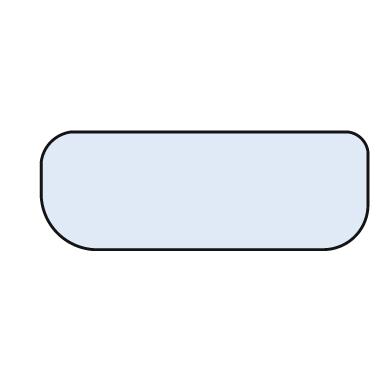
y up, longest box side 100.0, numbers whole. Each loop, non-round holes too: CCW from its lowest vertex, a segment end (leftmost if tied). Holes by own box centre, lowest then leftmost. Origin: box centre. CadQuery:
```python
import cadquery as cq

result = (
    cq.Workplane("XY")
    .moveTo(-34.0, -18.0)
    .lineTo(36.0, -18.0)
    .threePointArc((46.0, -14.0), (50.0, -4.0))
    .lineTo(50.0, 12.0)
    .threePointArc((48.0, 16.0), (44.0, 18.0))
    .lineTo(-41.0, 18.0)
    .threePointArc((-47.0, 15.0), (-50.0, 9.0))
    .lineTo(-50.0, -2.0)
    .threePointArc((-45.0, -13.0), (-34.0, -18.0))
    .close()
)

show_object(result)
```